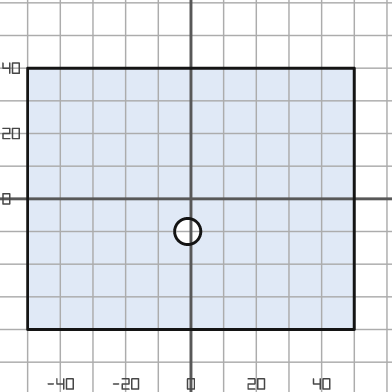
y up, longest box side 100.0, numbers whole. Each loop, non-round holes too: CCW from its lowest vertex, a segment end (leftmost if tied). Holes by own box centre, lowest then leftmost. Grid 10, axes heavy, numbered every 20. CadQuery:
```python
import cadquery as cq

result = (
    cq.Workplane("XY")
    .moveTo(-50.0, -40.0)
    .lineTo(50.0, -40.0)
    .lineTo(50.0, 40.0)
    .lineTo(-50.0, 40.0)
    .close()
    .moveTo(-1.0, -10.0)
    .circle(4.0)
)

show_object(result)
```